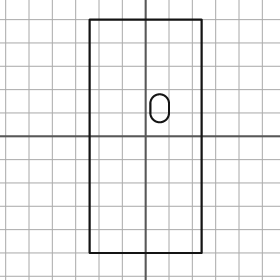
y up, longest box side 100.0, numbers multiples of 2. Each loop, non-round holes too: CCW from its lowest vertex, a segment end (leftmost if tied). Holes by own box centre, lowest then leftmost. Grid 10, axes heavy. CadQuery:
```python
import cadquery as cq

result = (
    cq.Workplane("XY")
    .moveTo(-24.0, -50.0)
    .lineTo(24.0, -50.0)
    .lineTo(24.0, 50.0)
    .lineTo(-24.0, 50.0)
    .close()
    .moveTo(2.0, 10.0)
    .threePointArc((6.0, 6.0), (10.0, 10.0))
    .lineTo(10.0, 14.0)
    .threePointArc((6.0, 18.0), (2.0, 14.0))
    .close()
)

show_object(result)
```